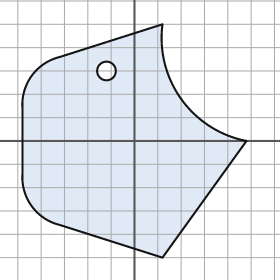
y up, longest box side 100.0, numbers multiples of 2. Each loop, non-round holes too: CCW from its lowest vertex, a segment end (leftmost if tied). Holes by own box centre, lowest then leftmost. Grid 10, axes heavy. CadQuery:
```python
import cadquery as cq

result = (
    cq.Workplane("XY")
    .moveTo(12.0, -50.0)
    .lineTo(48.0, 0.0)
    .threePointArc((20.0, 18.0), (12.0, 50.0))
    .lineTo(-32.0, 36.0)
    .threePointArc((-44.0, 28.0), (-48.0, 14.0))
    .lineTo(-48.0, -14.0)
    .threePointArc((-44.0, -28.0), (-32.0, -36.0))
    .close()
    .moveTo(-12.0, 30.0)
    .circle(4.0)
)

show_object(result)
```